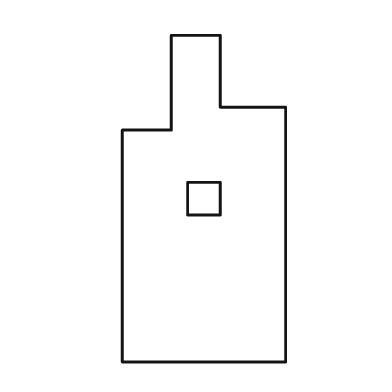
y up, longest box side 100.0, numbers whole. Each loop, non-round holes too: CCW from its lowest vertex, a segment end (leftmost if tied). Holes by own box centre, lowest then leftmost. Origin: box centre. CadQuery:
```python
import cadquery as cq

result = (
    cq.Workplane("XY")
    .moveTo(-25.0, -50.0)
    .lineTo(25.0, -50.0)
    .lineTo(25.0, 28.0)
    .lineTo(5.0, 28.0)
    .lineTo(5.0, 50.0)
    .lineTo(-10.0, 50.0)
    .lineTo(-10.0, 21.0)
    .lineTo(-25.0, 21.0)
    .close()
    .moveTo(-5.0, -5.0)
    .lineTo(5.0, -5.0)
    .lineTo(5.0, 5.0)
    .lineTo(-5.0, 5.0)
    .close()
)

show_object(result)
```